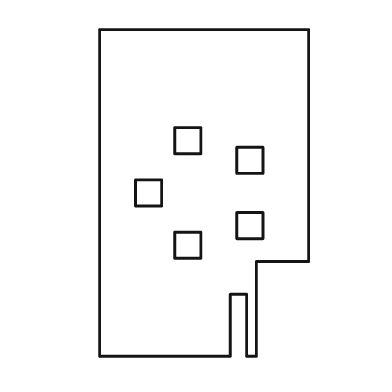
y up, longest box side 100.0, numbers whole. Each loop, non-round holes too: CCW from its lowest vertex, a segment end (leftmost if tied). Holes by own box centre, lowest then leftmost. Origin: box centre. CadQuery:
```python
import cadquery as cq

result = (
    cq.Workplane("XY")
    .moveTo(-32.0, -50.0)
    .lineTo(8.0, -50.0)
    .lineTo(8.0, -31.0)
    .lineTo(13.0, -31.0)
    .lineTo(13.0, -50.0)
    .lineTo(16.0, -50.0)
    .lineTo(16.0, -21.0)
    .lineTo(32.0, -21.0)
    .lineTo(32.0, 50.0)
    .lineTo(-32.0, 50.0)
    .close()
    .moveTo(-9.0, -20.0)
    .lineTo(-1.0, -20.0)
    .lineTo(-1.0, -12.0)
    .lineTo(-9.0, -12.0)
    .close()
    .moveTo(10.0, -14.0)
    .lineTo(18.0, -14.0)
    .lineTo(18.0, -6.0)
    .lineTo(10.0, -6.0)
    .close()
    .moveTo(-21.0, -4.0)
    .lineTo(-13.0, -4.0)
    .lineTo(-13.0, 4.0)
    .lineTo(-21.0, 4.0)
    .close()
    .moveTo(10.0, 6.0)
    .lineTo(18.0, 6.0)
    .lineTo(18.0, 14.0)
    .lineTo(10.0, 14.0)
    .close()
    .moveTo(-9.0, 12.0)
    .lineTo(-1.0, 12.0)
    .lineTo(-1.0, 20.0)
    .lineTo(-9.0, 20.0)
    .close()
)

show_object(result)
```